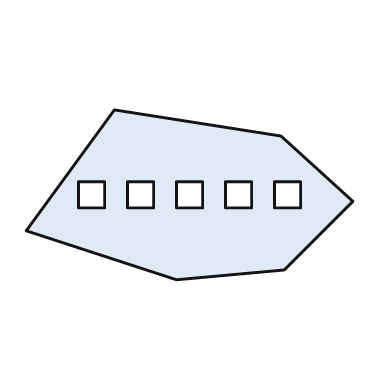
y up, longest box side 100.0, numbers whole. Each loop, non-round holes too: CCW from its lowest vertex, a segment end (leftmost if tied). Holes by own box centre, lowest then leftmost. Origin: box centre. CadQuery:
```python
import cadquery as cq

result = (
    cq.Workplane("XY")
    .moveTo(-4.0, -26.0)
    .lineTo(29.0, -23.0)
    .lineTo(50.0, -2.0)
    .lineTo(28.0, 18.0)
    .lineTo(-23.0, 26.0)
    .lineTo(-50.0, -11.0)
    .close()
    .moveTo(-34.0, -4.0)
    .lineTo(-26.0, -4.0)
    .lineTo(-26.0, 4.0)
    .lineTo(-34.0, 4.0)
    .close()
    .moveTo(-19.0, -4.0)
    .lineTo(-11.0, -4.0)
    .lineTo(-11.0, 4.0)
    .lineTo(-19.0, 4.0)
    .close()
    .moveTo(-4.0, -4.0)
    .lineTo(4.0, -4.0)
    .lineTo(4.0, 4.0)
    .lineTo(-4.0, 4.0)
    .close()
    .moveTo(11.0, -4.0)
    .lineTo(19.0, -4.0)
    .lineTo(19.0, 4.0)
    .lineTo(11.0, 4.0)
    .close()
    .moveTo(26.0, -4.0)
    .lineTo(34.0, -4.0)
    .lineTo(34.0, 4.0)
    .lineTo(26.0, 4.0)
    .close()
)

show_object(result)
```